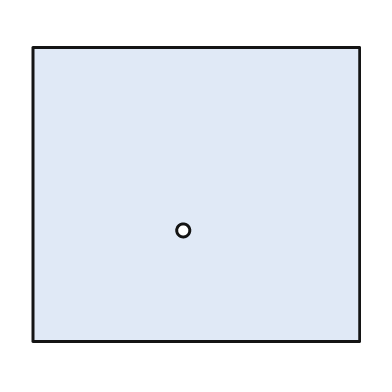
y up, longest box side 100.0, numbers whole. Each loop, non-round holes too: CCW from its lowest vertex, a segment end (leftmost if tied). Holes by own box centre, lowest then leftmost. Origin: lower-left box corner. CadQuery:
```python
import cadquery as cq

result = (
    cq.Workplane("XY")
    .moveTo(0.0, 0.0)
    .lineTo(100.0, 0.0)
    .lineTo(100.0, 90.0)
    .lineTo(0.0, 90.0)
    .close()
    .moveTo(46.0, 34.0)
    .circle(2.0)
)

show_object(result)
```